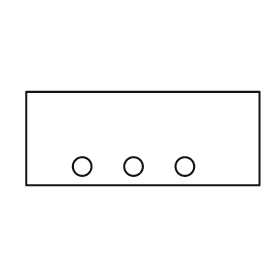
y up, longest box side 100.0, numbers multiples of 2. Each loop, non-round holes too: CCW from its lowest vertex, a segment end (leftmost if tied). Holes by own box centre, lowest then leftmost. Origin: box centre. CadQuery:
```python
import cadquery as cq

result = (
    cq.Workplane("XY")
    .moveTo(-50.0, -20.0)
    .lineTo(50.0, -20.0)
    .lineTo(50.0, 20.0)
    .lineTo(-50.0, 20.0)
    .close()
    .moveTo(-26.0, -12.0)
    .circle(4.0)
    .moveTo(-4.0, -12.0)
    .circle(4.0)
    .moveTo(18.0, -12.0)
    .circle(4.0)
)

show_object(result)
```